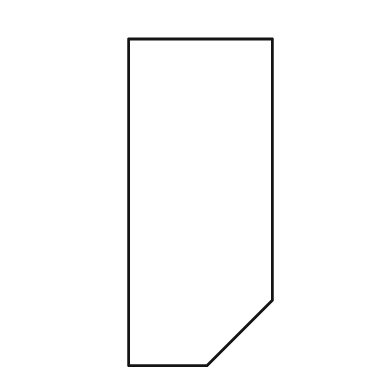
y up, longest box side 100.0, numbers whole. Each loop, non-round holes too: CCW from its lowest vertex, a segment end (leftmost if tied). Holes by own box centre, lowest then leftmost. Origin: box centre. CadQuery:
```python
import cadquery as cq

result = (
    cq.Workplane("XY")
    .moveTo(-22.0, -50.0)
    .lineTo(2.0, -50.0)
    .lineTo(22.0, -30.0)
    .lineTo(22.0, 50.0)
    .lineTo(-22.0, 50.0)
    .close()
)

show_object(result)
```